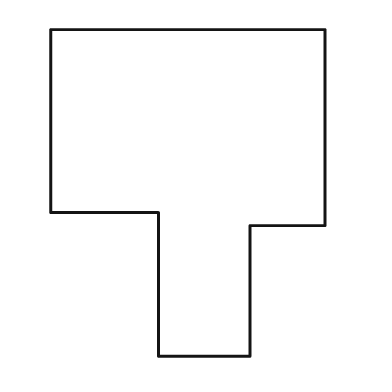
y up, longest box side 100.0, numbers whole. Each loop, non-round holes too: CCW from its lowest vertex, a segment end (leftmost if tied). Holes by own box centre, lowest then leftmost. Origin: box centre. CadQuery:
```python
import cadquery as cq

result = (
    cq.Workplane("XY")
    .moveTo(-9.0, -50.0)
    .lineTo(19.0, -50.0)
    .lineTo(19.0, -10.0)
    .lineTo(42.0, -10.0)
    .lineTo(42.0, 50.0)
    .lineTo(-42.0, 50.0)
    .lineTo(-42.0, -6.0)
    .lineTo(-9.0, -6.0)
    .close()
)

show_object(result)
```